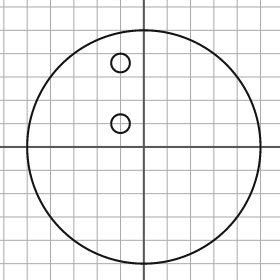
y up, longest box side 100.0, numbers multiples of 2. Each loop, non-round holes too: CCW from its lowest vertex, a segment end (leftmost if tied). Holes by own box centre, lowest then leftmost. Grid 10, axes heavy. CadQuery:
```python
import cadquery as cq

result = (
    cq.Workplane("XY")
    .moveTo(0.0, 0.0)
    .circle(50.0)
    .moveTo(-10.0, 10.0)
    .circle(4.0)
    .moveTo(-10.0, 36.0)
    .circle(4.0)
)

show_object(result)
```